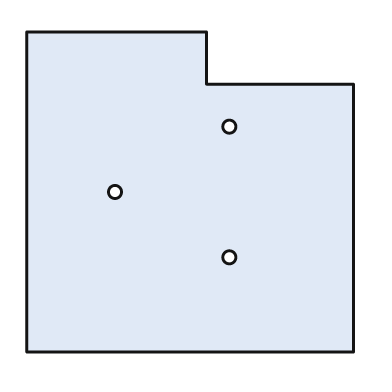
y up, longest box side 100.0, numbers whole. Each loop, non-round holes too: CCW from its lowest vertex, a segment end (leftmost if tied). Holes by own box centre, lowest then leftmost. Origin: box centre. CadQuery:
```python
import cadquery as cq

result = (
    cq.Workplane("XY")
    .moveTo(-50.0, -49.0)
    .lineTo(50.0, -49.0)
    .lineTo(50.0, 33.0)
    .lineTo(5.0, 33.0)
    .lineTo(5.0, 49.0)
    .lineTo(-50.0, 49.0)
    .close()
    .moveTo(12.0, -20.0)
    .circle(2.0)
    .moveTo(-23.0, 0.0)
    .circle(2.0)
    .moveTo(12.0, 20.0)
    .circle(2.0)
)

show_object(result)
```